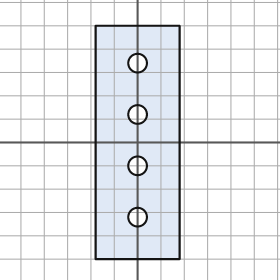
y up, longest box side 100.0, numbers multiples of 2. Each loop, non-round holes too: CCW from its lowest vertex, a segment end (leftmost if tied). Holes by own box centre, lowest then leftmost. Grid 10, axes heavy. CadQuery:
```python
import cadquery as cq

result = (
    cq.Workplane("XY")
    .moveTo(-18.0, -50.0)
    .lineTo(18.0, -50.0)
    .lineTo(18.0, 50.0)
    .lineTo(-18.0, 50.0)
    .close()
    .moveTo(0.0, -32.0)
    .circle(4.0)
    .moveTo(0.0, -10.0)
    .circle(4.0)
    .moveTo(0.0, 12.0)
    .circle(4.0)
    .moveTo(0.0, 34.0)
    .circle(4.0)
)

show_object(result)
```